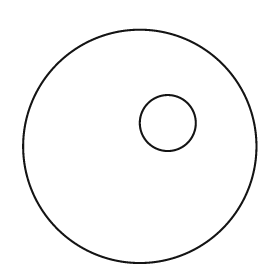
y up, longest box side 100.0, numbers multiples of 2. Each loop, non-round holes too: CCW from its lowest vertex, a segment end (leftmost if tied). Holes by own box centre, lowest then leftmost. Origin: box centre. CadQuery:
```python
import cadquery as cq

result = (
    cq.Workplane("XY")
    .moveTo(0.0, 0.0)
    .circle(50.0)
    .moveTo(12.0, 10.0)
    .circle(12.0)
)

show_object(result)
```